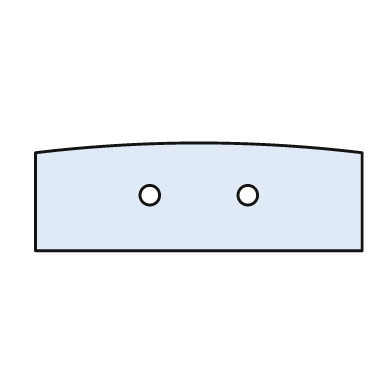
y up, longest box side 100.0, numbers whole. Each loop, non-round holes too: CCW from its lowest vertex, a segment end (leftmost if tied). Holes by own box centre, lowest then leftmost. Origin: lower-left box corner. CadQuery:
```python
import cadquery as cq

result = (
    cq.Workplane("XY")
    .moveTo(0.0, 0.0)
    .lineTo(100.0, 0.0)
    .lineTo(100.0, 30.0)
    .threePointArc((50.0, 33.0), (0.0, 30.0))
    .close()
    .moveTo(35.0, 17.0)
    .circle(3.0)
    .moveTo(65.0, 17.0)
    .circle(3.0)
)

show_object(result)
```